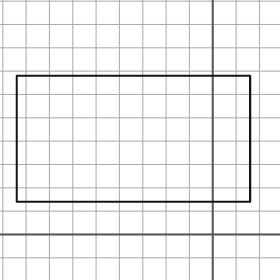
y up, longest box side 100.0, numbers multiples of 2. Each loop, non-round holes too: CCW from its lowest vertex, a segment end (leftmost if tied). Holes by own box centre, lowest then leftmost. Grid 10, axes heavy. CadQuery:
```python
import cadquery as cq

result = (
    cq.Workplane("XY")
    .moveTo(-84.0, 14.0)
    .lineTo(16.0, 14.0)
    .lineTo(16.0, 68.0)
    .lineTo(-84.0, 68.0)
    .close()
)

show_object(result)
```